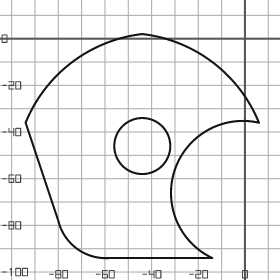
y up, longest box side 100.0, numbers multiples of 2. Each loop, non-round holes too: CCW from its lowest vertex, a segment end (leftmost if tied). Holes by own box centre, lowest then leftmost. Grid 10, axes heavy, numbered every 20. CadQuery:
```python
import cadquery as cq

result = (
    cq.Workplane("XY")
    .moveTo(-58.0, -94.0)
    .lineTo(-14.0, -94.0)
    .threePointArc((-30.0, -56.0), (6.0, -36.0))
    .threePointArc((-14.0, -10.0), (-44.0, 2.0))
    .threePointArc((-74.0, -10.0), (-94.0, -36.0))
    .lineTo(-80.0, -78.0)
    .threePointArc((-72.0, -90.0), (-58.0, -94.0))
    .close()
    .moveTo(-44.0, -46.0)
    .circle(12.0)
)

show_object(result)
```